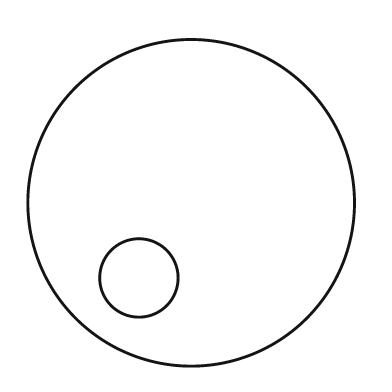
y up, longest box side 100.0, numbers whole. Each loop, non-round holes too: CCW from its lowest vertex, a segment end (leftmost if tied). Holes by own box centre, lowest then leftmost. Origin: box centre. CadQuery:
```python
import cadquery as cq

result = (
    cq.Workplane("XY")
    .moveTo(0.0, 0.0)
    .circle(50.0)
    .moveTo(-16.0, -23.0)
    .circle(12.0)
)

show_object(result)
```